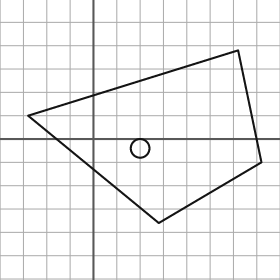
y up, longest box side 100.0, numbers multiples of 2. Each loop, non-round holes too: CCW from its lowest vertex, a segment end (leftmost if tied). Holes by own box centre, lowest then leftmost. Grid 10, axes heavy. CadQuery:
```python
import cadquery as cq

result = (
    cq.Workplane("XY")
    .moveTo(28.0, -36.0)
    .lineTo(72.0, -10.0)
    .lineTo(62.0, 38.0)
    .lineTo(-28.0, 10.0)
    .close()
    .moveTo(20.0, -4.0)
    .circle(4.0)
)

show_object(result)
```